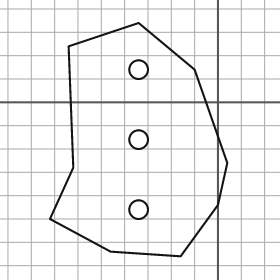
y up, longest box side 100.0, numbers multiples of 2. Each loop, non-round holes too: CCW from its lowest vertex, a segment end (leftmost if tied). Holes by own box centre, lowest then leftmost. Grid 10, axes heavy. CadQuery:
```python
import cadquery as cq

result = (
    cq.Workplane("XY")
    .moveTo(-16.0, -66.0)
    .lineTo(0.0, -44.0)
    .lineTo(4.0, -26.0)
    .lineTo(-10.0, 14.0)
    .lineTo(-34.0, 34.0)
    .lineTo(-64.0, 24.0)
    .lineTo(-62.0, -28.0)
    .lineTo(-72.0, -50.0)
    .lineTo(-46.0, -64.0)
    .close()
    .moveTo(-34.0, -46.0)
    .circle(4.0)
    .moveTo(-34.0, -16.0)
    .circle(4.0)
    .moveTo(-34.0, 14.0)
    .circle(4.0)
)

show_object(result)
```